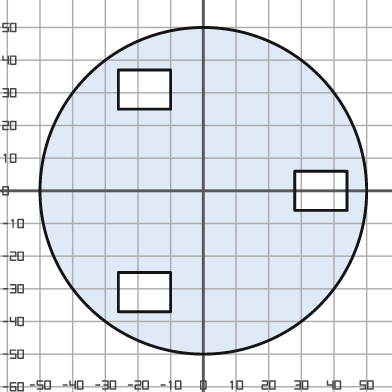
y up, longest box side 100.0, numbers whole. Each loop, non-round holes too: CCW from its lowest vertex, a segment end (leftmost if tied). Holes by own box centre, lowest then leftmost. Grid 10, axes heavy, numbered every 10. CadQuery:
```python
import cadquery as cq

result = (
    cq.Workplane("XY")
    .moveTo(0.0, 0.0)
    .circle(50.0)
    .moveTo(-26.0, -37.0)
    .lineTo(-10.0, -37.0)
    .lineTo(-10.0, -25.0)
    .lineTo(-26.0, -25.0)
    .close()
    .moveTo(28.0, -6.0)
    .lineTo(44.0, -6.0)
    .lineTo(44.0, 6.0)
    .lineTo(28.0, 6.0)
    .close()
    .moveTo(-26.0, 25.0)
    .lineTo(-10.0, 25.0)
    .lineTo(-10.0, 37.0)
    .lineTo(-26.0, 37.0)
    .close()
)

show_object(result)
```